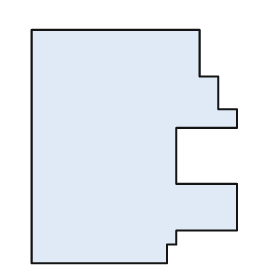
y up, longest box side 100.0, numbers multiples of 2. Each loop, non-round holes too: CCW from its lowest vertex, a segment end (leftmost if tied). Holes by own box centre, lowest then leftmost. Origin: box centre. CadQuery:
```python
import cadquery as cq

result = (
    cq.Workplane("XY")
    .moveTo(-44.0, -50.0)
    .lineTo(14.0, -50.0)
    .lineTo(14.0, -42.0)
    .lineTo(18.0, -42.0)
    .lineTo(18.0, -36.0)
    .lineTo(44.0, -36.0)
    .lineTo(44.0, -16.0)
    .lineTo(18.0, -16.0)
    .lineTo(18.0, 8.0)
    .lineTo(44.0, 8.0)
    .lineTo(44.0, 16.0)
    .lineTo(36.0, 16.0)
    .lineTo(36.0, 30.0)
    .lineTo(28.0, 30.0)
    .lineTo(28.0, 50.0)
    .lineTo(-44.0, 50.0)
    .close()
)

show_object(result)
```